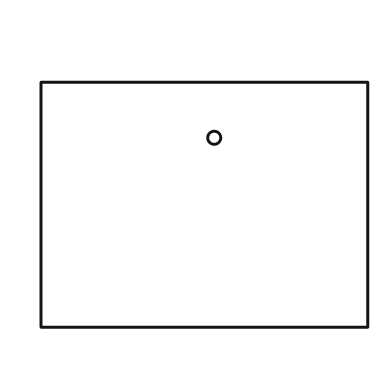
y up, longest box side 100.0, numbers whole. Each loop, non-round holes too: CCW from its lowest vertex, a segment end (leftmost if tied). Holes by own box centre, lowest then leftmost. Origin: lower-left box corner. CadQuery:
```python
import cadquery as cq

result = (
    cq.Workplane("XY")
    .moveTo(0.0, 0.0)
    .lineTo(100.0, 0.0)
    .lineTo(100.0, 75.0)
    .lineTo(0.0, 75.0)
    .close()
    .moveTo(53.0, 58.0)
    .circle(2.0)
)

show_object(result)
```